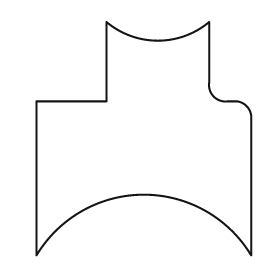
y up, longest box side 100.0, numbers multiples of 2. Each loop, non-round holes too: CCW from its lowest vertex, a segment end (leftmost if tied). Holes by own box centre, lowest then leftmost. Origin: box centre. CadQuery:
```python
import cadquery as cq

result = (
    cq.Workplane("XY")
    .moveTo(-46.0, -50.0)
    .threePointArc((0.0, -24.0), (46.0, -50.0))
    .lineTo(46.0, 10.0)
    .threePointArc((44.0, 14.0), (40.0, 16.0))
    .lineTo(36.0, 16.0)
    .threePointArc((30.0, 18.0), (28.0, 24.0))
    .lineTo(28.0, 50.0)
    .threePointArc((6.0, 42.0), (-16.0, 50.0))
    .lineTo(-16.0, 16.0)
    .lineTo(-46.0, 16.0)
    .close()
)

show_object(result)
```